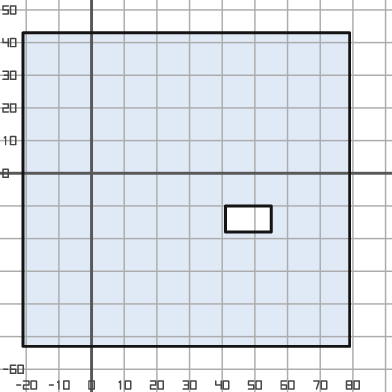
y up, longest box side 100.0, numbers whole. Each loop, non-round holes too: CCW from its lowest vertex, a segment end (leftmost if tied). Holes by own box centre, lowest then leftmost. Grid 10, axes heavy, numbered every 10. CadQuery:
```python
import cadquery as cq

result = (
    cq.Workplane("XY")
    .moveTo(-21.0, -53.0)
    .lineTo(79.0, -53.0)
    .lineTo(79.0, 43.0)
    .lineTo(-21.0, 43.0)
    .close()
    .moveTo(41.0, -18.0)
    .lineTo(55.0, -18.0)
    .lineTo(55.0, -10.0)
    .lineTo(41.0, -10.0)
    .close()
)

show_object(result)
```